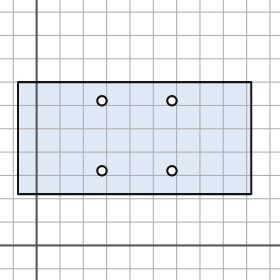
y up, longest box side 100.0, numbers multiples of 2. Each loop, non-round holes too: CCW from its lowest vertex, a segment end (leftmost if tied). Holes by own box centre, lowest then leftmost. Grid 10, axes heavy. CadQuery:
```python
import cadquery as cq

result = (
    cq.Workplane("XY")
    .moveTo(-8.0, 22.0)
    .lineTo(92.0, 22.0)
    .lineTo(92.0, 70.0)
    .lineTo(-8.0, 70.0)
    .close()
    .moveTo(28.0, 32.0)
    .circle(2.0)
    .moveTo(58.0, 32.0)
    .circle(2.0)
    .moveTo(28.0, 62.0)
    .circle(2.0)
    .moveTo(58.0, 62.0)
    .circle(2.0)
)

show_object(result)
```